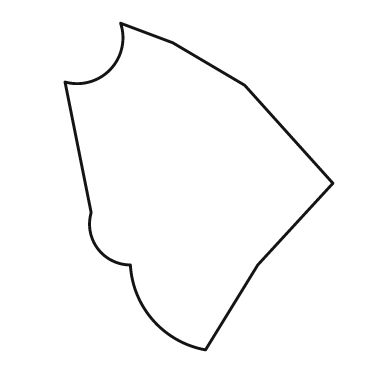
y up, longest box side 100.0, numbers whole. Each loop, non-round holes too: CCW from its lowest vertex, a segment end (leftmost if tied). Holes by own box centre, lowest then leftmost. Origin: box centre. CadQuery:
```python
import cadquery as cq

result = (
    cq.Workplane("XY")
    .moveTo(2.0, -50.0)
    .lineTo(18.0, -24.0)
    .lineTo(41.0, 1.0)
    .lineTo(14.0, 31.0)
    .lineTo(-8.0, 44.0)
    .lineTo(-24.0, 50.0)
    .threePointArc((-27.0, 36.0), (-41.0, 32.0))
    .lineTo(-33.0, -8.0)
    .threePointArc((-31.0, -19.0), (-21.0, -24.0))
    .threePointArc((-14.0, -41.0), (2.0, -50.0))
    .close()
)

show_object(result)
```